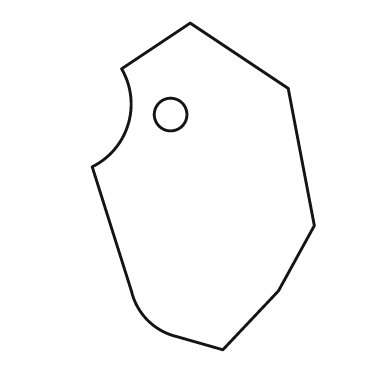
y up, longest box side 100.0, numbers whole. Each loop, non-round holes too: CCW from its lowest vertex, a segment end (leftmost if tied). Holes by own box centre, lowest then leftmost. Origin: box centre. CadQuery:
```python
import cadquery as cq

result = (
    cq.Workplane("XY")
    .moveTo(6.0, -50.0)
    .lineTo(23.0, -32.0)
    .lineTo(34.0, -12.0)
    .lineTo(26.0, 30.0)
    .lineTo(-4.0, 50.0)
    .lineTo(-25.0, 36.0)
    .threePointArc((-23.0, 19.0), (-34.0, 6.0))
    .lineTo(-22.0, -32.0)
    .threePointArc((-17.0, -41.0), (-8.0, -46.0))
    .close()
    .moveTo(-10.0, 22.0)
    .circle(5.0)
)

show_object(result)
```